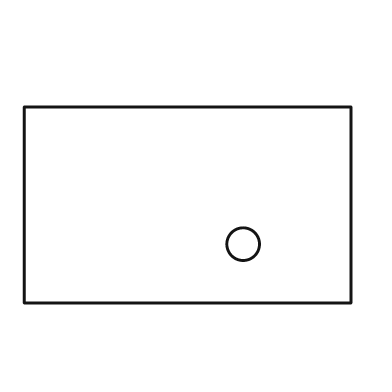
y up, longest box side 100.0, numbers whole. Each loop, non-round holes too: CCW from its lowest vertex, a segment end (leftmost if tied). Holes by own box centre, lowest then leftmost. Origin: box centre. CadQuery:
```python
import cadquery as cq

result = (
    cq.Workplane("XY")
    .moveTo(-50.0, -30.0)
    .lineTo(50.0, -30.0)
    .lineTo(50.0, 30.0)
    .lineTo(-50.0, 30.0)
    .close()
    .moveTo(17.0, -12.0)
    .circle(5.0)
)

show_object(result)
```